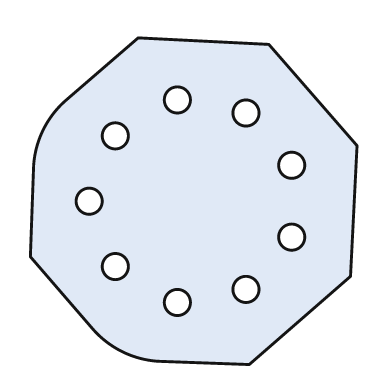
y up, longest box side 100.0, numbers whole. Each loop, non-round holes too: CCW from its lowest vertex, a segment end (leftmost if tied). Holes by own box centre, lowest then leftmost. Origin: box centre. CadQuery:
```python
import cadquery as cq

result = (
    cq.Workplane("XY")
    .moveTo(17.0, -50.0)
    .lineTo(48.0, -23.0)
    .lineTo(50.0, 17.0)
    .lineTo(23.0, 48.0)
    .lineTo(-17.0, 50.0)
    .lineTo(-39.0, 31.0)
    .threePointArc((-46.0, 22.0), (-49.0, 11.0))
    .lineTo(-50.0, -17.0)
    .lineTo(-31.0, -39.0)
    .threePointArc((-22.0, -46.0), (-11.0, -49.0))
    .close()
    .moveTo(-5.0, -31.0)
    .circle(4.0)
    .moveTo(16.0, -27.0)
    .circle(4.0)
    .moveTo(-24.0, -20.0)
    .circle(4.0)
    .moveTo(30.0, -11.0)
    .circle(4.0)
    .moveTo(-32.0, 0.0)
    .circle(4.0)
    .moveTo(30.0, 11.0)
    .circle(4.0)
    .moveTo(-24.0, 20.0)
    .circle(4.0)
    .moveTo(16.0, 27.0)
    .circle(4.0)
    .moveTo(-5.0, 31.0)
    .circle(4.0)
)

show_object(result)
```